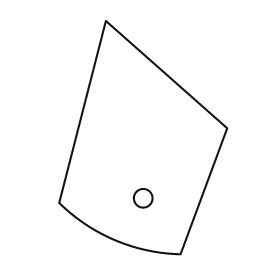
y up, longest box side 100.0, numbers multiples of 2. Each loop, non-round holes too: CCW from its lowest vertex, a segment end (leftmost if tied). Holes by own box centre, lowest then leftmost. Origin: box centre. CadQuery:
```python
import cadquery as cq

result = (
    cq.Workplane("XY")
    .moveTo(16.0, -50.0)
    .lineTo(36.0, 4.0)
    .lineTo(-16.0, 50.0)
    .lineTo(-36.0, -28.0)
    .threePointArc((-12.0, -44.0), (16.0, -50.0))
    .close()
    .moveTo(0.0, -26.0)
    .circle(4.0)
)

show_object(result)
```